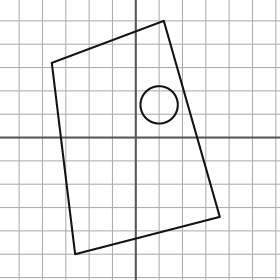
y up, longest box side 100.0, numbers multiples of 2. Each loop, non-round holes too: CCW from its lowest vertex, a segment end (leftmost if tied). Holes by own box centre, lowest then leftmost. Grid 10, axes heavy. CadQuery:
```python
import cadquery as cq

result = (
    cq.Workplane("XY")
    .moveTo(-26.0, -50.0)
    .lineTo(36.0, -34.0)
    .lineTo(12.0, 50.0)
    .lineTo(-36.0, 32.0)
    .close()
    .moveTo(10.0, 14.0)
    .circle(8.0)
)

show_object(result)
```